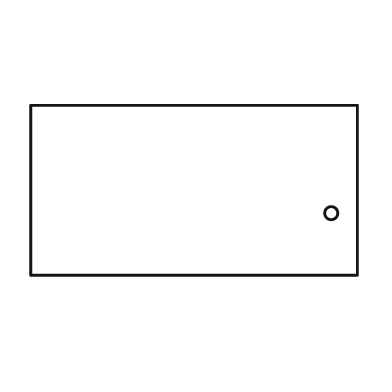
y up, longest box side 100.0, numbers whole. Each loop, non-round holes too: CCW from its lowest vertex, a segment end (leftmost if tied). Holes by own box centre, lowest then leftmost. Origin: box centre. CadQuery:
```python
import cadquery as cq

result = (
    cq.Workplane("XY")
    .moveTo(-50.0, -26.0)
    .lineTo(50.0, -26.0)
    .lineTo(50.0, 26.0)
    .lineTo(-50.0, 26.0)
    .close()
    .moveTo(42.0, -7.0)
    .circle(2.0)
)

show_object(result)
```